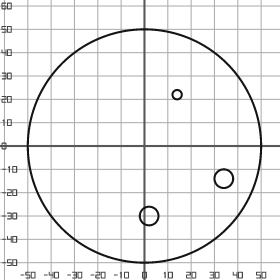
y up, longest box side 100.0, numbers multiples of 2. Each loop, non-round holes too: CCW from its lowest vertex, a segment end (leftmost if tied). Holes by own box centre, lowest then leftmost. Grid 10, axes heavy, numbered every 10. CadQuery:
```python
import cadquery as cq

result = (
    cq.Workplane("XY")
    .moveTo(0.0, 0.0)
    .circle(50.0)
    .moveTo(2.0, -30.0)
    .circle(4.0)
    .moveTo(34.0, -14.0)
    .circle(4.0)
    .moveTo(14.0, 22.0)
    .circle(2.0)
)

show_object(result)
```